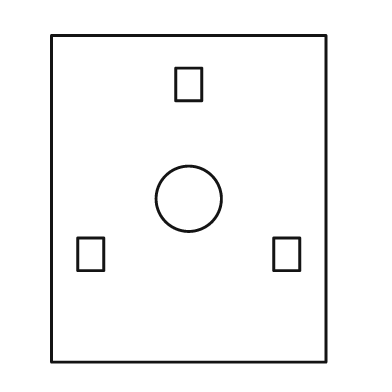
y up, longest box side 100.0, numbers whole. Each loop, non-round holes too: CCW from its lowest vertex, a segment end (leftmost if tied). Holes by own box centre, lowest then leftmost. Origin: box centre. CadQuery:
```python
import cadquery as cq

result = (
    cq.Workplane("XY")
    .moveTo(-42.0, -50.0)
    .lineTo(42.0, -50.0)
    .lineTo(42.0, 50.0)
    .lineTo(-42.0, 50.0)
    .close()
    .moveTo(-34.0, -22.0)
    .lineTo(-26.0, -22.0)
    .lineTo(-26.0, -12.0)
    .lineTo(-34.0, -12.0)
    .close()
    .moveTo(26.0, -22.0)
    .lineTo(34.0, -22.0)
    .lineTo(34.0, -12.0)
    .lineTo(26.0, -12.0)
    .close()
    .moveTo(0.0, 0.0)
    .circle(10.0)
    .moveTo(-4.0, 30.0)
    .lineTo(4.0, 30.0)
    .lineTo(4.0, 40.0)
    .lineTo(-4.0, 40.0)
    .close()
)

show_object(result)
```